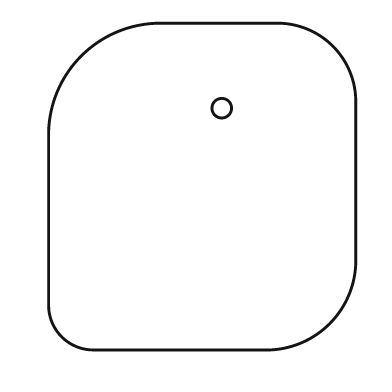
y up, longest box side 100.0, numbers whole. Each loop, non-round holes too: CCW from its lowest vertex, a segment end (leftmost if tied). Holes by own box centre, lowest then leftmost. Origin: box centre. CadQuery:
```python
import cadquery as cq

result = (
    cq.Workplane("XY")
    .moveTo(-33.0, -50.0)
    .lineTo(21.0, -50.0)
    .threePointArc((39.0, -42.0), (47.0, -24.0))
    .lineTo(47.0, 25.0)
    .threePointArc((40.0, 43.0), (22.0, 50.0))
    .lineTo(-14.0, 50.0)
    .threePointArc((-37.0, 40.0), (-47.0, 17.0))
    .lineTo(-47.0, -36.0)
    .threePointArc((-43.0, -46.0), (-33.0, -50.0))
    .close()
    .moveTo(6.0, 24.0)
    .circle(3.0)
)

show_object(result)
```